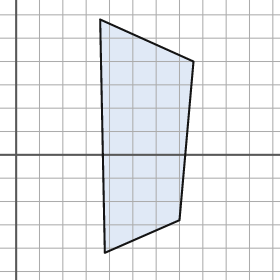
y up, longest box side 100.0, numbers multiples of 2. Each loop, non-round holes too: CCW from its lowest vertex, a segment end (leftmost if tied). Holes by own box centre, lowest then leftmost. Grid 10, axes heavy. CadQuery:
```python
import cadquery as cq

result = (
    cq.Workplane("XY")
    .moveTo(38.0, -42.0)
    .lineTo(70.0, -28.0)
    .lineTo(76.0, 40.0)
    .lineTo(36.0, 58.0)
    .close()
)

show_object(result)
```